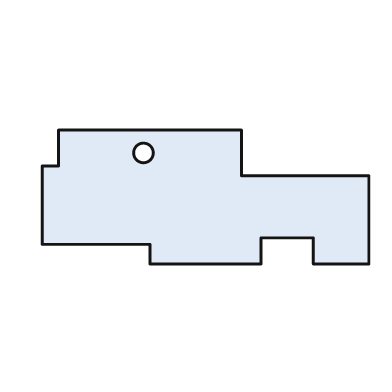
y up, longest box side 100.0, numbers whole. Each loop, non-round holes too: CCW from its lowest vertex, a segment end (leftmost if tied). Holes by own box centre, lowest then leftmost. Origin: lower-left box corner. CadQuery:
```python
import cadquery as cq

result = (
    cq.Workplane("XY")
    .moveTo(33.0, 0.0)
    .lineTo(67.0, 0.0)
    .lineTo(67.0, 8.0)
    .lineTo(83.0, 8.0)
    .lineTo(83.0, 0.0)
    .lineTo(100.0, 0.0)
    .lineTo(100.0, 27.0)
    .lineTo(61.0, 27.0)
    .lineTo(61.0, 41.0)
    .lineTo(5.0, 41.0)
    .lineTo(5.0, 30.0)
    .lineTo(0.0, 30.0)
    .lineTo(0.0, 6.0)
    .lineTo(33.0, 6.0)
    .close()
    .moveTo(31.0, 34.0)
    .circle(3.0)
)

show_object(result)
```